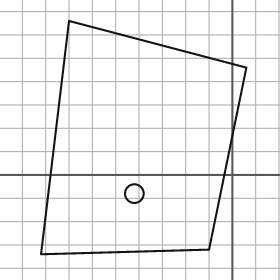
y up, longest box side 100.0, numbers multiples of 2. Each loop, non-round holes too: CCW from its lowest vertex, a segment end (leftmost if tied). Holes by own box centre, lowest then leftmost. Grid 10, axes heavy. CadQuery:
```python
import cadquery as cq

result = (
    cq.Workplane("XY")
    .moveTo(-82.0, -34.0)
    .lineTo(-10.0, -32.0)
    .lineTo(6.0, 46.0)
    .lineTo(-70.0, 66.0)
    .close()
    .moveTo(-42.0, -8.0)
    .circle(4.0)
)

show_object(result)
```